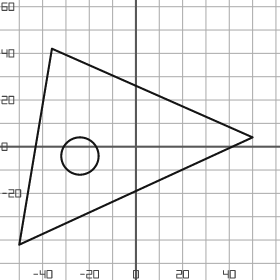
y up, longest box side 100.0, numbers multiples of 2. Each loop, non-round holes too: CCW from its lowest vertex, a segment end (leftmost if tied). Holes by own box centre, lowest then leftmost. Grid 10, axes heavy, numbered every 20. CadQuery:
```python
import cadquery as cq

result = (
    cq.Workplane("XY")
    .moveTo(-50.0, -42.0)
    .lineTo(50.0, 4.0)
    .lineTo(-36.0, 42.0)
    .close()
    .moveTo(-24.0, -4.0)
    .circle(8.0)
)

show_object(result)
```